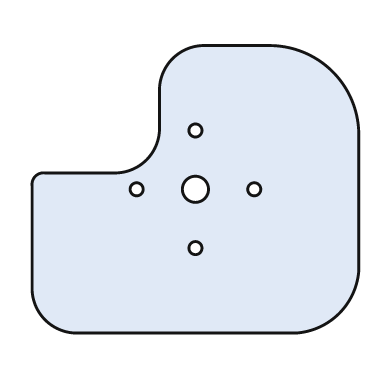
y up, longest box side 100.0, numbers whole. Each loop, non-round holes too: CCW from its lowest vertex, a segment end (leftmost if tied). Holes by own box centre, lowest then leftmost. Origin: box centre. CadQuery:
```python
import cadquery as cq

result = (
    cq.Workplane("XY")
    .moveTo(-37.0, -44.0)
    .lineTo(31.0, -44.0)
    .threePointArc((44.0, -38.0), (50.0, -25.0))
    .lineTo(50.0, 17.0)
    .threePointArc((42.0, 36.0), (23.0, 44.0))
    .lineTo(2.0, 44.0)
    .threePointArc((-7.0, 40.0), (-11.0, 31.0))
    .lineTo(-11.0, 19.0)
    .threePointArc((-15.0, 9.0), (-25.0, 5.0))
    .lineTo(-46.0, 5.0)
    .threePointArc((-49.0, 4.0), (-50.0, 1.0))
    .lineTo(-50.0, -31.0)
    .threePointArc((-46.0, -40.0), (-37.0, -44.0))
    .close()
    .moveTo(0.0, -18.0)
    .circle(2.0)
    .moveTo(-18.0, 0.0)
    .circle(2.0)
    .moveTo(0.0, 0.0)
    .circle(4.0)
    .moveTo(18.0, 0.0)
    .circle(2.0)
    .moveTo(0.0, 18.0)
    .circle(2.0)
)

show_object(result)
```